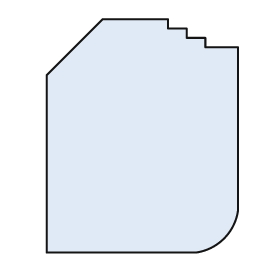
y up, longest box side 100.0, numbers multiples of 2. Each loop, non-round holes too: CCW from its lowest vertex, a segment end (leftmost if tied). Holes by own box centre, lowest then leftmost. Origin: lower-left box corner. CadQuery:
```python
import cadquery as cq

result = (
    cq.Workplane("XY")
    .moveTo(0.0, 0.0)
    .lineTo(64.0, 0.0)
    .threePointArc((76.0, 6.0), (82.0, 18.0))
    .lineTo(82.0, 88.0)
    .lineTo(68.0, 88.0)
    .lineTo(68.0, 92.0)
    .lineTo(60.0, 92.0)
    .lineTo(60.0, 96.0)
    .lineTo(52.0, 96.0)
    .lineTo(52.0, 100.0)
    .lineTo(24.0, 100.0)
    .lineTo(0.0, 76.0)
    .close()
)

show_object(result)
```